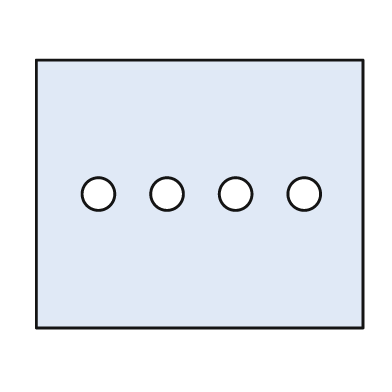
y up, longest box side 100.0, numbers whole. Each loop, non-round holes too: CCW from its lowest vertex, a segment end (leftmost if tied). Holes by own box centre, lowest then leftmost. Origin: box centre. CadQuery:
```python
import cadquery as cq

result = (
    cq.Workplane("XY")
    .moveTo(-50.0, -41.0)
    .lineTo(50.0, -41.0)
    .lineTo(50.0, 41.0)
    .lineTo(-50.0, 41.0)
    .close()
    .moveTo(-31.0, 0.0)
    .circle(5.0)
    .moveTo(-10.0, 0.0)
    .circle(5.0)
    .moveTo(11.0, 0.0)
    .circle(5.0)
    .moveTo(32.0, 0.0)
    .circle(5.0)
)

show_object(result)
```